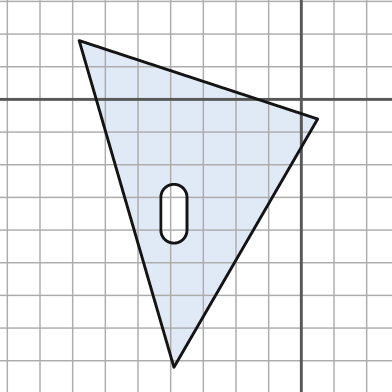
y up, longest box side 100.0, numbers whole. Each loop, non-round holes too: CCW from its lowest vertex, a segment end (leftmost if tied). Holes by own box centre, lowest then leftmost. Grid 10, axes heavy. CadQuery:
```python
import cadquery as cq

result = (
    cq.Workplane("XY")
    .moveTo(-39.0, -82.0)
    .lineTo(5.0, -6.0)
    .lineTo(-68.0, 18.0)
    .close()
    .moveTo(-43.0, -40.0)
    .threePointArc((-39.0, -44.0), (-35.0, -40.0))
    .lineTo(-35.0, -30.0)
    .threePointArc((-39.0, -26.0), (-43.0, -30.0))
    .close()
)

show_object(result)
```